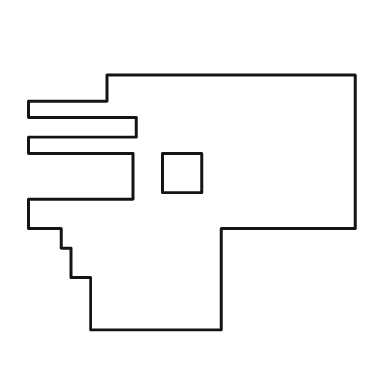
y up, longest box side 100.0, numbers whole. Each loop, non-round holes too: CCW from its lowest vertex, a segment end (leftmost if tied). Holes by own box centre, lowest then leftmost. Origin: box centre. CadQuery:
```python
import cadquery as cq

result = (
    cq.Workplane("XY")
    .moveTo(-31.0, -39.0)
    .lineTo(9.0, -39.0)
    .lineTo(9.0, -8.0)
    .lineTo(50.0, -8.0)
    .lineTo(50.0, 39.0)
    .lineTo(-26.0, 39.0)
    .lineTo(-26.0, 31.0)
    .lineTo(-50.0, 31.0)
    .lineTo(-50.0, 26.0)
    .lineTo(-17.0, 26.0)
    .lineTo(-17.0, 20.0)
    .lineTo(-50.0, 20.0)
    .lineTo(-50.0, 15.0)
    .lineTo(-18.0, 15.0)
    .lineTo(-18.0, 1.0)
    .lineTo(-50.0, 1.0)
    .lineTo(-50.0, -8.0)
    .lineTo(-40.0, -8.0)
    .lineTo(-40.0, -14.0)
    .lineTo(-37.0, -14.0)
    .lineTo(-37.0, -23.0)
    .lineTo(-31.0, -23.0)
    .close()
    .moveTo(-9.0, 3.0)
    .lineTo(3.0, 3.0)
    .lineTo(3.0, 15.0)
    .lineTo(-9.0, 15.0)
    .close()
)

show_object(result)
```